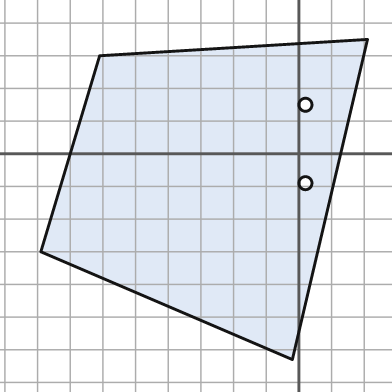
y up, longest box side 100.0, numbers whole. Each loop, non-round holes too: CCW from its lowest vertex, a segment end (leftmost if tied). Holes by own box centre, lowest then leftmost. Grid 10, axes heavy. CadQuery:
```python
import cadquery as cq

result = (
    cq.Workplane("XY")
    .moveTo(-2.0, -63.0)
    .lineTo(21.0, 35.0)
    .lineTo(-61.0, 30.0)
    .lineTo(-79.0, -30.0)
    .close()
    .moveTo(2.0, -9.0)
    .circle(2.0)
    .moveTo(2.0, 15.0)
    .circle(2.0)
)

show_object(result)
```